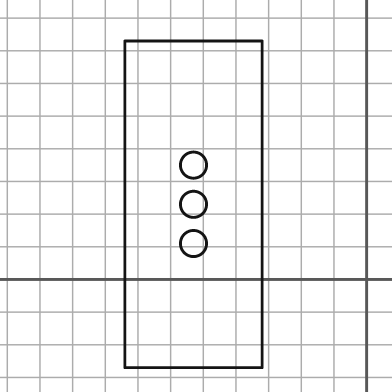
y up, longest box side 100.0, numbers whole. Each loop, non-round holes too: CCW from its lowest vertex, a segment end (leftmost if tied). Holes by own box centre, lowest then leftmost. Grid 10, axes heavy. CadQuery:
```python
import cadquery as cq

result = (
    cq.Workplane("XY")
    .moveTo(-74.0, -27.0)
    .lineTo(-32.0, -27.0)
    .lineTo(-32.0, 73.0)
    .lineTo(-74.0, 73.0)
    .close()
    .moveTo(-53.0, 11.0)
    .circle(4.0)
    .moveTo(-53.0, 23.0)
    .circle(4.0)
    .moveTo(-53.0, 35.0)
    .circle(4.0)
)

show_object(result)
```